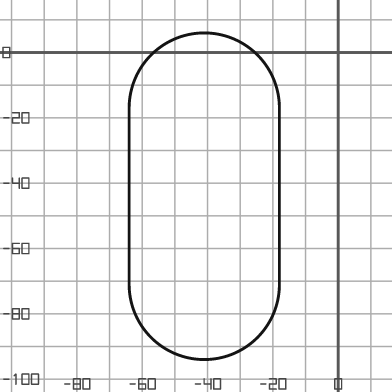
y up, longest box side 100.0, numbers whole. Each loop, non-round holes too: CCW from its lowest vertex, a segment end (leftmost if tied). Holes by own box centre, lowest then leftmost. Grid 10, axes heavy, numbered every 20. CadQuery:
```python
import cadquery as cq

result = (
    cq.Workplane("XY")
    .moveTo(-64.0, -71.0)
    .threePointArc((-41.0, -94.0), (-18.0, -71.0))
    .lineTo(-18.0, -17.0)
    .threePointArc((-41.0, 6.0), (-64.0, -17.0))
    .close()
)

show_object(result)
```